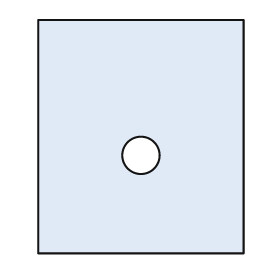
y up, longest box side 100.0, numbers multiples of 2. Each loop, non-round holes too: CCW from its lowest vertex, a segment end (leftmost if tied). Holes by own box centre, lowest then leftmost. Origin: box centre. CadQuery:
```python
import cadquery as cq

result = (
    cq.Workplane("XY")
    .moveTo(-44.0, -50.0)
    .lineTo(44.0, -50.0)
    .lineTo(44.0, 50.0)
    .lineTo(-44.0, 50.0)
    .close()
    .moveTo(0.0, -8.0)
    .circle(8.0)
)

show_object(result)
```